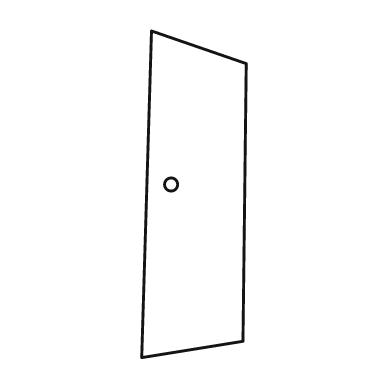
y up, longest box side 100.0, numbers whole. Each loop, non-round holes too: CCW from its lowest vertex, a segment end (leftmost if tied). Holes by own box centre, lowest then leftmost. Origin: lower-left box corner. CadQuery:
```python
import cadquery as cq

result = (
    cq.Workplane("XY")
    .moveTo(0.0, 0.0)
    .lineTo(31.0, 5.0)
    .lineTo(32.0, 90.0)
    .lineTo(3.0, 100.0)
    .close()
    .moveTo(9.0, 53.0)
    .circle(2.0)
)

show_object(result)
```